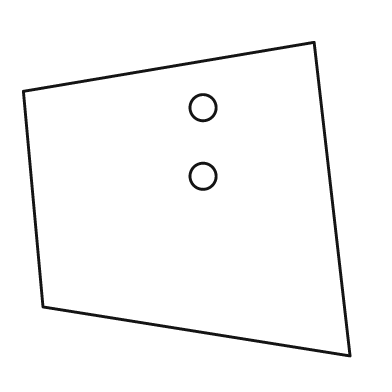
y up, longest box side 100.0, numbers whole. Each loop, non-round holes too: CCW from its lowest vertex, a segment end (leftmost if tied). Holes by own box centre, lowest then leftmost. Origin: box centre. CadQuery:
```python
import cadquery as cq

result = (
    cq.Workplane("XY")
    .moveTo(50.0, -48.0)
    .lineTo(39.0, 48.0)
    .lineTo(-50.0, 33.0)
    .lineTo(-44.0, -33.0)
    .close()
    .moveTo(5.0, 7.0)
    .circle(4.0)
    .moveTo(5.0, 28.0)
    .circle(4.0)
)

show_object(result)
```